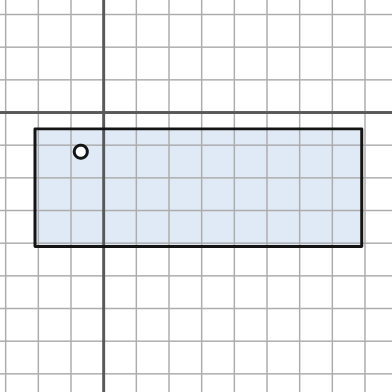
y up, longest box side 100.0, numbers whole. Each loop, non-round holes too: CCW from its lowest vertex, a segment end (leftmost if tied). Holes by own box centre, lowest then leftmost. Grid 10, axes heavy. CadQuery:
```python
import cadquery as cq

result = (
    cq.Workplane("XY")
    .moveTo(-21.0, -41.0)
    .lineTo(79.0, -41.0)
    .lineTo(79.0, -5.0)
    .lineTo(-21.0, -5.0)
    .close()
    .moveTo(-7.0, -12.0)
    .circle(2.0)
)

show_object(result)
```